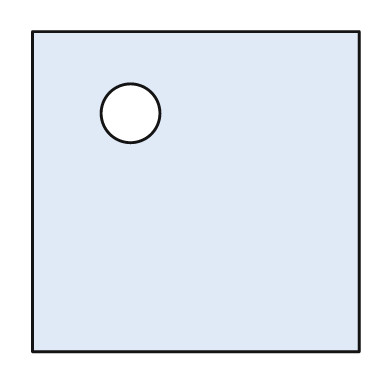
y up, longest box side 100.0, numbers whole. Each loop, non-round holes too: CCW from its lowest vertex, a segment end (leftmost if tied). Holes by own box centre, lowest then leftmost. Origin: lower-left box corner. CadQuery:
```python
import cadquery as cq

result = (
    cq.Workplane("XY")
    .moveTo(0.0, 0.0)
    .lineTo(100.0, 0.0)
    .lineTo(100.0, 98.0)
    .lineTo(0.0, 98.0)
    .close()
    .moveTo(30.0, 73.0)
    .circle(9.0)
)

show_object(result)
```